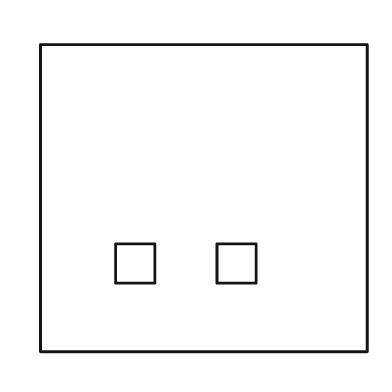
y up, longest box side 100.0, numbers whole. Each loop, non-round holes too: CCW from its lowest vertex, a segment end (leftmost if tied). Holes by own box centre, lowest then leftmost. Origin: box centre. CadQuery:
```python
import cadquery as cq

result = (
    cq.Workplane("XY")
    .moveTo(-50.0, -47.0)
    .lineTo(50.0, -47.0)
    .lineTo(50.0, 47.0)
    .lineTo(-50.0, 47.0)
    .close()
    .moveTo(-27.0, -26.0)
    .lineTo(-15.0, -26.0)
    .lineTo(-15.0, -14.0)
    .lineTo(-27.0, -14.0)
    .close()
    .moveTo(4.0, -26.0)
    .lineTo(16.0, -26.0)
    .lineTo(16.0, -14.0)
    .lineTo(4.0, -14.0)
    .close()
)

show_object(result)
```